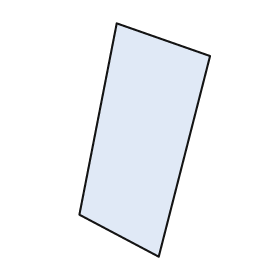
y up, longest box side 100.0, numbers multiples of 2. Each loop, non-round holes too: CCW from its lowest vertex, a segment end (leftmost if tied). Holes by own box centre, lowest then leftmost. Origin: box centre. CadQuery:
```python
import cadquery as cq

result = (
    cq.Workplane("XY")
    .moveTo(6.0, -50.0)
    .lineTo(28.0, 36.0)
    .lineTo(-12.0, 50.0)
    .lineTo(-28.0, -32.0)
    .close()
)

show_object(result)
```